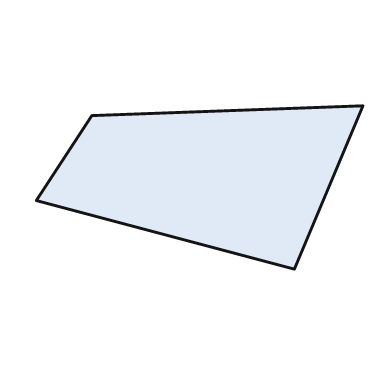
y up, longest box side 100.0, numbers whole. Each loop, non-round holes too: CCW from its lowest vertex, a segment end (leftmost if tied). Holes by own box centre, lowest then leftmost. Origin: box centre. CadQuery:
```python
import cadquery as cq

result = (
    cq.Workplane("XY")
    .moveTo(29.0, -25.0)
    .lineTo(50.0, 25.0)
    .lineTo(-33.0, 22.0)
    .lineTo(-50.0, -4.0)
    .close()
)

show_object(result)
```